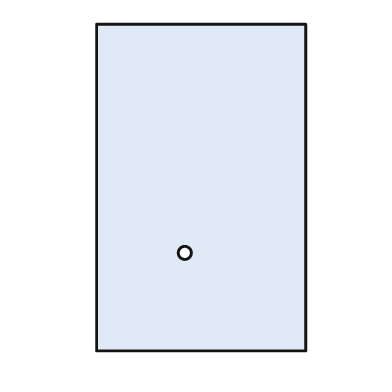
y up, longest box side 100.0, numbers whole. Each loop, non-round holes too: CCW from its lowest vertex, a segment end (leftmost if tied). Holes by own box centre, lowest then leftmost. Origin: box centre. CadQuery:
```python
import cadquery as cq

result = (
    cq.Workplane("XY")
    .moveTo(-32.0, -50.0)
    .lineTo(32.0, -50.0)
    .lineTo(32.0, 50.0)
    .lineTo(-32.0, 50.0)
    .close()
    .moveTo(-5.0, -20.0)
    .circle(2.0)
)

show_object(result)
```